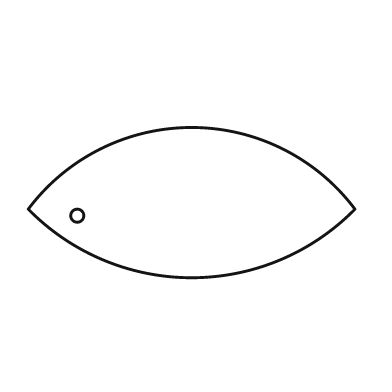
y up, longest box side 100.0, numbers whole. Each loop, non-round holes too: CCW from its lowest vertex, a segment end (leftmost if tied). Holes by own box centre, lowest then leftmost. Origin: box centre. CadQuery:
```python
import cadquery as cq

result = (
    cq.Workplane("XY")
    .moveTo(-50.0, -2.0)
    .threePointArc((0.0, -23.0), (50.0, -2.0))
    .threePointArc((0.0, 23.0), (-50.0, -2.0))
    .close()
    .moveTo(-35.0, -4.0)
    .circle(2.0)
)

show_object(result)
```